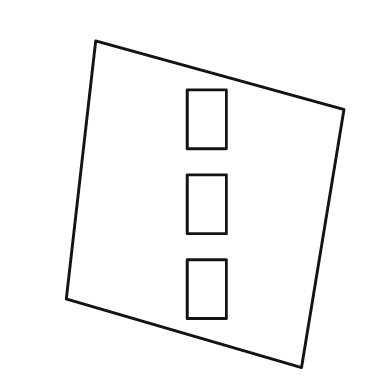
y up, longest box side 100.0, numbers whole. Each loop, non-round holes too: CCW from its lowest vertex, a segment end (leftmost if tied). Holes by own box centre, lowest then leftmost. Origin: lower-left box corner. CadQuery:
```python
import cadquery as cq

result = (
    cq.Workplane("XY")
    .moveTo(72.0, 0.0)
    .lineTo(85.0, 79.0)
    .lineTo(9.0, 100.0)
    .lineTo(0.0, 21.0)
    .close()
    .moveTo(37.0, 15.0)
    .lineTo(49.0, 15.0)
    .lineTo(49.0, 33.0)
    .lineTo(37.0, 33.0)
    .close()
    .moveTo(37.0, 41.0)
    .lineTo(49.0, 41.0)
    .lineTo(49.0, 59.0)
    .lineTo(37.0, 59.0)
    .close()
    .moveTo(37.0, 67.0)
    .lineTo(49.0, 67.0)
    .lineTo(49.0, 85.0)
    .lineTo(37.0, 85.0)
    .close()
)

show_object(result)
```